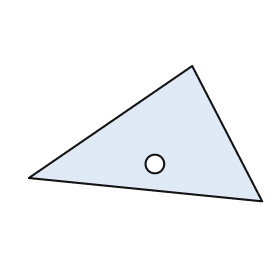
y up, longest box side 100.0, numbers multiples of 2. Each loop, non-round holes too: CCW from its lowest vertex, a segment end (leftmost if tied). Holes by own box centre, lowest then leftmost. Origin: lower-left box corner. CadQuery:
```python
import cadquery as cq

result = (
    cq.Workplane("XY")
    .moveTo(100.0, 0.0)
    .lineTo(70.0, 58.0)
    .lineTo(0.0, 10.0)
    .close()
    .moveTo(54.0, 16.0)
    .circle(4.0)
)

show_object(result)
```